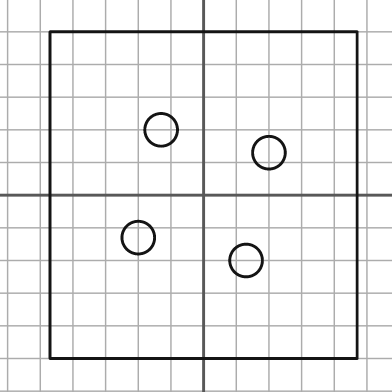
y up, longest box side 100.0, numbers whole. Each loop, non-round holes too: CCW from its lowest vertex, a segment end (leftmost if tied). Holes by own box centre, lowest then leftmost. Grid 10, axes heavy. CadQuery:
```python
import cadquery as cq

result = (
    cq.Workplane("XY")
    .moveTo(-47.0, -50.0)
    .lineTo(47.0, -50.0)
    .lineTo(47.0, 50.0)
    .lineTo(-47.0, 50.0)
    .close()
    .moveTo(13.0, -20.0)
    .circle(5.0)
    .moveTo(-20.0, -13.0)
    .circle(5.0)
    .moveTo(20.0, 13.0)
    .circle(5.0)
    .moveTo(-13.0, 20.0)
    .circle(5.0)
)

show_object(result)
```